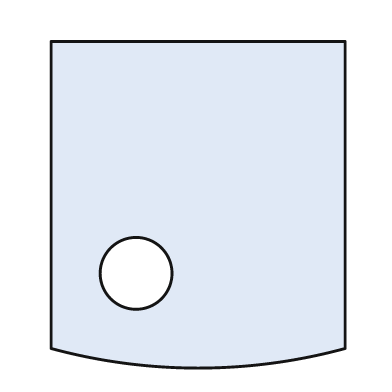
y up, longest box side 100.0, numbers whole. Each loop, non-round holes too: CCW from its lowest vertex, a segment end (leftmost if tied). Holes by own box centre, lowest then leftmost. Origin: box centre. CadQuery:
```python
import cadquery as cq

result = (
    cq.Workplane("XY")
    .moveTo(-45.0, -44.0)
    .threePointArc((0.0, -50.0), (45.0, -44.0))
    .lineTo(45.0, 50.0)
    .lineTo(-45.0, 50.0)
    .close()
    .moveTo(-19.0, -21.0)
    .circle(11.0)
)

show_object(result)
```